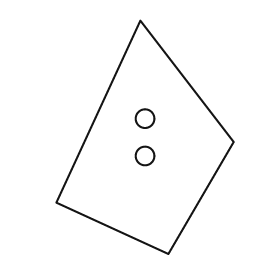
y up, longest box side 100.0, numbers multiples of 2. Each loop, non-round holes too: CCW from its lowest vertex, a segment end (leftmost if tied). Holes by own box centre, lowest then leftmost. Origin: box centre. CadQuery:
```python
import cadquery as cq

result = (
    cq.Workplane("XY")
    .moveTo(10.0, -50.0)
    .lineTo(38.0, -2.0)
    .lineTo(-2.0, 50.0)
    .lineTo(-38.0, -28.0)
    .close()
    .moveTo(0.0, -8.0)
    .circle(4.0)
    .moveTo(0.0, 8.0)
    .circle(4.0)
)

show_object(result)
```